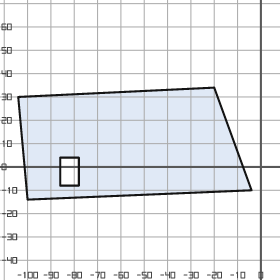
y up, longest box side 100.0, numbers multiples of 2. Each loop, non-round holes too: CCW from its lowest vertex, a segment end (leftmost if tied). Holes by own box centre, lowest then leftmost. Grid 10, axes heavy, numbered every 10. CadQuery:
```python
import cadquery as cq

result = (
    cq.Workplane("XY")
    .moveTo(-100.0, -14.0)
    .lineTo(-4.0, -10.0)
    .lineTo(-20.0, 34.0)
    .lineTo(-104.0, 30.0)
    .close()
    .moveTo(-86.0, -8.0)
    .lineTo(-78.0, -8.0)
    .lineTo(-78.0, 4.0)
    .lineTo(-86.0, 4.0)
    .close()
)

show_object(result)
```